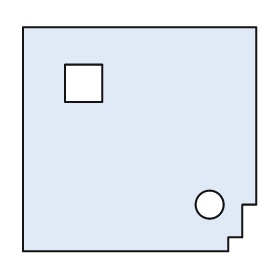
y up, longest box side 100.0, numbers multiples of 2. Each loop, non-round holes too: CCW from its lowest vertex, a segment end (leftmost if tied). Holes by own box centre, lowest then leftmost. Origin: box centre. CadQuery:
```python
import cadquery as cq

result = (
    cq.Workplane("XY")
    .moveTo(-50.0, -48.0)
    .lineTo(38.0, -48.0)
    .lineTo(38.0, -42.0)
    .lineTo(44.0, -42.0)
    .lineTo(44.0, -28.0)
    .lineTo(50.0, -28.0)
    .lineTo(50.0, 48.0)
    .lineTo(-50.0, 48.0)
    .close()
    .moveTo(30.0, -28.0)
    .circle(6.0)
    .moveTo(-32.0, 16.0)
    .lineTo(-16.0, 16.0)
    .lineTo(-16.0, 32.0)
    .lineTo(-32.0, 32.0)
    .close()
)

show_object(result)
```